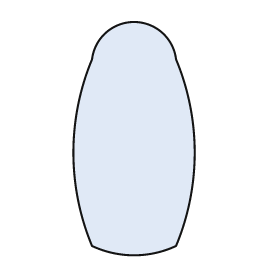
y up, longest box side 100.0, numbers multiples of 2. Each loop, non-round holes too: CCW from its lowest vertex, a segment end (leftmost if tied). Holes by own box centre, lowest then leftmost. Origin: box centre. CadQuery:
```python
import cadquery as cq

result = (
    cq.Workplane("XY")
    .moveTo(-18.0, -46.0)
    .threePointArc((0.0, -50.0), (18.0, -46.0))
    .threePointArc((26.0, -6.0), (18.0, 34.0))
    .threePointArc((0.0, 50.0), (-18.0, 34.0))
    .threePointArc((-26.0, -6.0), (-18.0, -46.0))
    .close()
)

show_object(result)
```